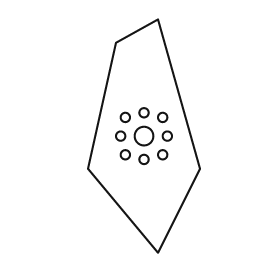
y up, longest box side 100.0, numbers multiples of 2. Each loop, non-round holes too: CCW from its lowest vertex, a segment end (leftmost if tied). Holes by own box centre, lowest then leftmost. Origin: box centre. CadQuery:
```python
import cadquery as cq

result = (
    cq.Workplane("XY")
    .moveTo(6.0, -50.0)
    .lineTo(24.0, -14.0)
    .lineTo(6.0, 50.0)
    .lineTo(-12.0, 40.0)
    .lineTo(-24.0, -14.0)
    .close()
    .moveTo(0.0, -10.0)
    .circle(2.0)
    .moveTo(-8.0, -8.0)
    .circle(2.0)
    .moveTo(8.0, -8.0)
    .circle(2.0)
    .moveTo(-10.0, 0.0)
    .circle(2.0)
    .moveTo(0.0, 0.0)
    .circle(4.0)
    .moveTo(10.0, 0.0)
    .circle(2.0)
    .moveTo(-8.0, 8.0)
    .circle(2.0)
    .moveTo(8.0, 8.0)
    .circle(2.0)
    .moveTo(0.0, 10.0)
    .circle(2.0)
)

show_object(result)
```